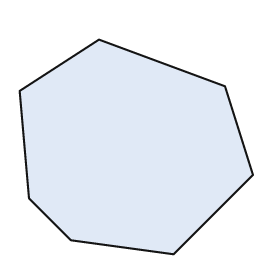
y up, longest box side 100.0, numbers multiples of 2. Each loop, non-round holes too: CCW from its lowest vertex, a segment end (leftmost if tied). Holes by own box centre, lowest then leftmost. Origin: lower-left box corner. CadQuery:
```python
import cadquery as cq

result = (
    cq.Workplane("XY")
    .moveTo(66.0, 0.0)
    .lineTo(100.0, 34.0)
    .lineTo(88.0, 72.0)
    .lineTo(34.0, 92.0)
    .lineTo(0.0, 70.0)
    .lineTo(4.0, 24.0)
    .lineTo(22.0, 6.0)
    .close()
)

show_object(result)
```